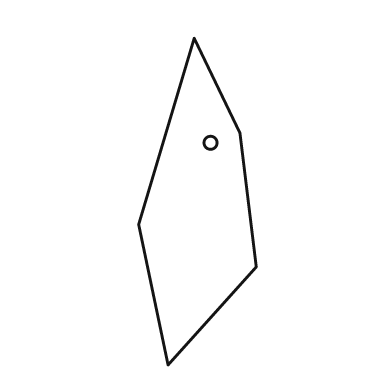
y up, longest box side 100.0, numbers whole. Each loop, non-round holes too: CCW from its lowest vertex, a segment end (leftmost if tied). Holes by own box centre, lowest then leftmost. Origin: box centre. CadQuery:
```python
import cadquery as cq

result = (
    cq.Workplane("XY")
    .moveTo(-9.0, -50.0)
    .lineTo(18.0, -20.0)
    .lineTo(13.0, 21.0)
    .lineTo(-1.0, 50.0)
    .lineTo(-18.0, -7.0)
    .close()
    .moveTo(4.0, 18.0)
    .circle(2.0)
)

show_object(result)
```